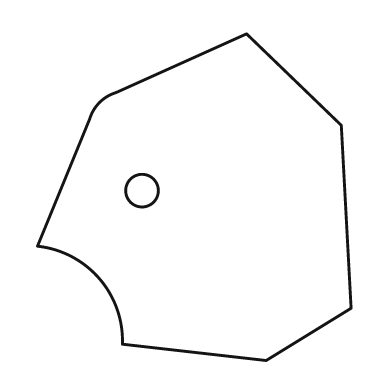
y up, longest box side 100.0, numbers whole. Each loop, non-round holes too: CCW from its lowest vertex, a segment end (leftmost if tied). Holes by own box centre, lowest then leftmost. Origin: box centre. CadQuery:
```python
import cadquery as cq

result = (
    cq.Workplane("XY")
    .moveTo(22.0, -50.0)
    .lineTo(48.0, -34.0)
    .lineTo(45.0, 22.0)
    .lineTo(16.0, 50.0)
    .lineTo(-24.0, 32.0)
    .threePointArc((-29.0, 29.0), (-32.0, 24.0))
    .lineTo(-48.0, -15.0)
    .threePointArc((-29.0, -25.0), (-22.0, -45.0))
    .close()
    .moveTo(-16.0, 2.0)
    .circle(5.0)
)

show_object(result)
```